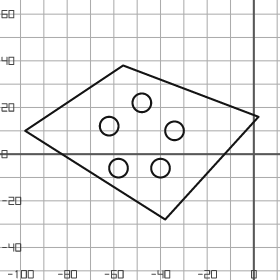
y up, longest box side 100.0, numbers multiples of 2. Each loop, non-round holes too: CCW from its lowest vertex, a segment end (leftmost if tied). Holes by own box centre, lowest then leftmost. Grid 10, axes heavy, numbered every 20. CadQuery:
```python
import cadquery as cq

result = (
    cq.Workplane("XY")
    .moveTo(-38.0, -28.0)
    .lineTo(2.0, 16.0)
    .lineTo(-56.0, 38.0)
    .lineTo(-98.0, 10.0)
    .close()
    .moveTo(-58.0, -6.0)
    .circle(4.0)
    .moveTo(-40.0, -6.0)
    .circle(4.0)
    .moveTo(-34.0, 10.0)
    .circle(4.0)
    .moveTo(-62.0, 12.0)
    .circle(4.0)
    .moveTo(-48.0, 22.0)
    .circle(4.0)
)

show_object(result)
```